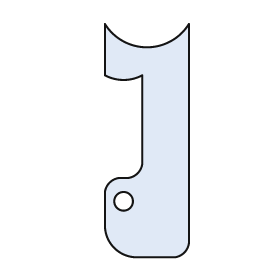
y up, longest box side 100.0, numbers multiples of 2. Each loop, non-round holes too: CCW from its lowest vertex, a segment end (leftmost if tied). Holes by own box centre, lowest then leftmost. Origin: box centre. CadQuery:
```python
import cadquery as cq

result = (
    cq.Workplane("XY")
    .moveTo(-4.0, -50.0)
    .lineTo(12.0, -50.0)
    .threePointArc((16.0, -48.0), (18.0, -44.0))
    .lineTo(18.0, 50.0)
    .threePointArc((0.0, 40.0), (-18.0, 50.0))
    .lineTo(-18.0, 28.0)
    .threePointArc((-10.0, 26.0), (-2.0, 28.0))
    .lineTo(-2.0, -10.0)
    .threePointArc((-4.0, -14.0), (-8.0, -16.0))
    .lineTo(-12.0, -16.0)
    .threePointArc((-16.0, -18.0), (-18.0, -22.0))
    .lineTo(-18.0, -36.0)
    .threePointArc((-14.0, -46.0), (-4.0, -50.0))
    .close()
    .moveTo(-10.0, -26.0)
    .circle(4.0)
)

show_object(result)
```